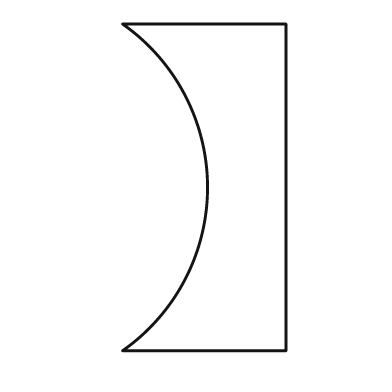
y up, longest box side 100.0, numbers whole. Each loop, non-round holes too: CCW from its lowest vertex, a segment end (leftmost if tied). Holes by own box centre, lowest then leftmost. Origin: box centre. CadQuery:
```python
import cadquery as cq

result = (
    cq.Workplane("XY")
    .moveTo(-25.0, -50.0)
    .lineTo(25.0, -50.0)
    .lineTo(25.0, 50.0)
    .lineTo(-25.0, 50.0)
    .threePointArc((1.0, 0.0), (-25.0, -50.0))
    .close()
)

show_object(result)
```